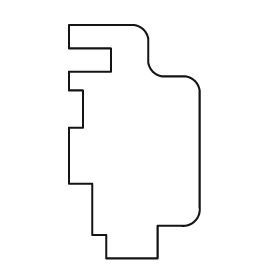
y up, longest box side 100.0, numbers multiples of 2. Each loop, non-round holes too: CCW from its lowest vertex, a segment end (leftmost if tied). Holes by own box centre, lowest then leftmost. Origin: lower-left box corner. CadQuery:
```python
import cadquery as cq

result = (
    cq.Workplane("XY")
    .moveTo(16.0, 0.0)
    .lineTo(38.0, 0.0)
    .lineTo(38.0, 14.0)
    .lineTo(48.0, 14.0)
    .threePointArc((54.0, 16.0), (56.0, 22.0))
    .lineTo(56.0, 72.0)
    .threePointArc((54.0, 76.0), (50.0, 78.0))
    .lineTo(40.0, 78.0)
    .threePointArc((36.0, 80.0), (34.0, 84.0))
    .lineTo(34.0, 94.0)
    .threePointArc((32.0, 98.0), (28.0, 100.0))
    .lineTo(0.0, 100.0)
    .lineTo(0.0, 90.0)
    .lineTo(18.0, 90.0)
    .lineTo(18.0, 80.0)
    .lineTo(0.0, 80.0)
    .lineTo(0.0, 72.0)
    .lineTo(6.0, 72.0)
    .lineTo(6.0, 56.0)
    .lineTo(0.0, 56.0)
    .lineTo(0.0, 32.0)
    .lineTo(10.0, 32.0)
    .lineTo(10.0, 10.0)
    .lineTo(16.0, 10.0)
    .close()
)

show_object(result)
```